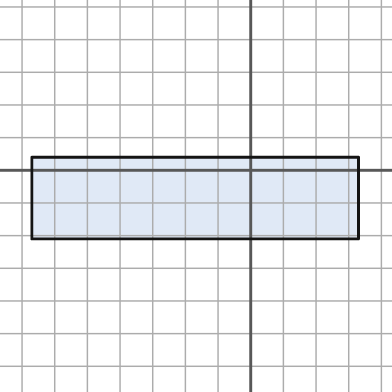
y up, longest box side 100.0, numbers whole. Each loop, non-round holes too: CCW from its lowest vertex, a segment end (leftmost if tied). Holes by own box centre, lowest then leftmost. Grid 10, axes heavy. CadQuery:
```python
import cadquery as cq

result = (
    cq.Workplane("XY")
    .moveTo(-67.0, -21.0)
    .lineTo(33.0, -21.0)
    .lineTo(33.0, 4.0)
    .lineTo(-67.0, 4.0)
    .close()
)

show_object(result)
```